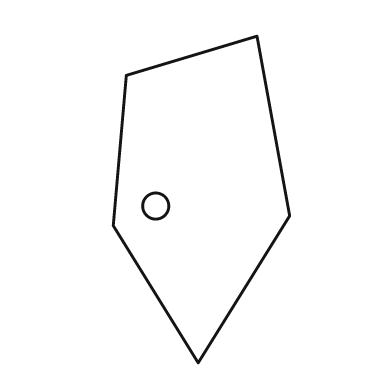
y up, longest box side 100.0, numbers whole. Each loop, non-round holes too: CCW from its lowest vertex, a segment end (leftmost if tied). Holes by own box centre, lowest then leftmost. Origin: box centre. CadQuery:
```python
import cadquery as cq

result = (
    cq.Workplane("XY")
    .moveTo(-1.0, -50.0)
    .lineTo(27.0, -5.0)
    .lineTo(17.0, 50.0)
    .lineTo(-23.0, 38.0)
    .lineTo(-27.0, -8.0)
    .close()
    .moveTo(-14.0, -2.0)
    .circle(4.0)
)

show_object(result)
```